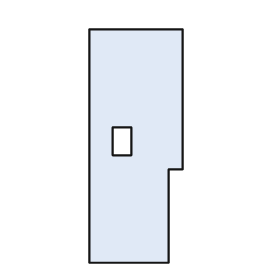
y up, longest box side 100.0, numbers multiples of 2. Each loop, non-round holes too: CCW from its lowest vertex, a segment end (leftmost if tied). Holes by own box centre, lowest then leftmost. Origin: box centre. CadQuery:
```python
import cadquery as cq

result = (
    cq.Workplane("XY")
    .moveTo(-20.0, -50.0)
    .lineTo(14.0, -50.0)
    .lineTo(14.0, -10.0)
    .lineTo(20.0, -10.0)
    .lineTo(20.0, 50.0)
    .lineTo(-20.0, 50.0)
    .close()
    .moveTo(-10.0, -4.0)
    .lineTo(-2.0, -4.0)
    .lineTo(-2.0, 8.0)
    .lineTo(-10.0, 8.0)
    .close()
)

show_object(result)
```